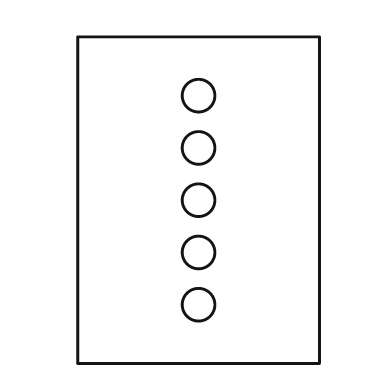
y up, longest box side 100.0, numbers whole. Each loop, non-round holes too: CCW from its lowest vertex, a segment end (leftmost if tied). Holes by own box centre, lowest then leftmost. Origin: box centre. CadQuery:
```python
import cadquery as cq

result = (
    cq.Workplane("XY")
    .moveTo(-37.0, -50.0)
    .lineTo(37.0, -50.0)
    .lineTo(37.0, 50.0)
    .lineTo(-37.0, 50.0)
    .close()
    .moveTo(0.0, -32.0)
    .circle(5.0)
    .moveTo(0.0, -16.0)
    .circle(5.0)
    .moveTo(0.0, 0.0)
    .circle(5.0)
    .moveTo(0.0, 16.0)
    .circle(5.0)
    .moveTo(0.0, 32.0)
    .circle(5.0)
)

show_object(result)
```